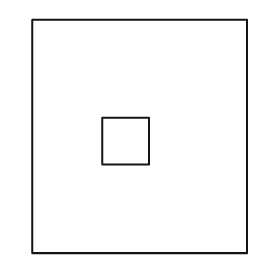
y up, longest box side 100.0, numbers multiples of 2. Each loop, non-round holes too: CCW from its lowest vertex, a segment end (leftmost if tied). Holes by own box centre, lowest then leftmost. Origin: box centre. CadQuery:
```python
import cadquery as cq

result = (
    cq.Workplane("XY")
    .moveTo(-46.0, -50.0)
    .lineTo(46.0, -50.0)
    .lineTo(46.0, 50.0)
    .lineTo(-46.0, 50.0)
    .close()
    .moveTo(-16.0, -12.0)
    .lineTo(4.0, -12.0)
    .lineTo(4.0, 8.0)
    .lineTo(-16.0, 8.0)
    .close()
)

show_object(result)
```